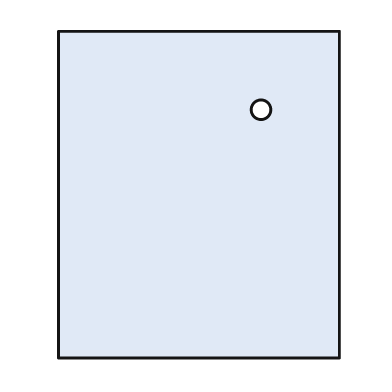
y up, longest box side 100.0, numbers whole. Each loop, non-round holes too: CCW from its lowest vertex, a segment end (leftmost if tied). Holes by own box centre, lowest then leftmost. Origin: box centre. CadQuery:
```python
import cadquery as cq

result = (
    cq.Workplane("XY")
    .moveTo(-43.0, -50.0)
    .lineTo(43.0, -50.0)
    .lineTo(43.0, 50.0)
    .lineTo(-43.0, 50.0)
    .close()
    .moveTo(19.0, 26.0)
    .circle(3.0)
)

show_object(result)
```